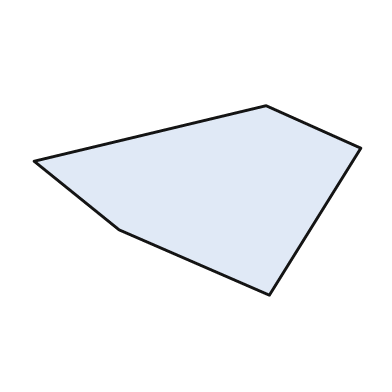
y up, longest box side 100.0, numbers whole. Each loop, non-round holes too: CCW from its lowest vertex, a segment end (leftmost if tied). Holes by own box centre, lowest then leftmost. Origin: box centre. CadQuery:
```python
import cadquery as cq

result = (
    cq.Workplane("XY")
    .moveTo(22.0, -29.0)
    .lineTo(50.0, 16.0)
    .lineTo(21.0, 29.0)
    .lineTo(-50.0, 12.0)
    .lineTo(-24.0, -9.0)
    .close()
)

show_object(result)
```